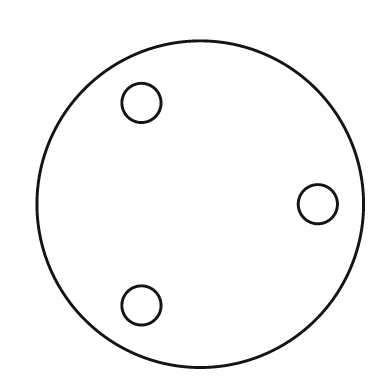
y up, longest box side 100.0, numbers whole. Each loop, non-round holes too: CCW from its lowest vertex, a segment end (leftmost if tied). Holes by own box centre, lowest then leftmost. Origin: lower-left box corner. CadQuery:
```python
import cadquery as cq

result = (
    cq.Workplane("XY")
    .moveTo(50.0, 50.0)
    .circle(50.0)
    .moveTo(32.0, 19.0)
    .circle(6.0)
    .moveTo(86.0, 50.0)
    .circle(6.0)
    .moveTo(32.0, 81.0)
    .circle(6.0)
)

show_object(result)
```